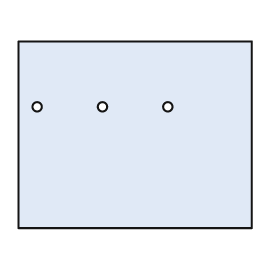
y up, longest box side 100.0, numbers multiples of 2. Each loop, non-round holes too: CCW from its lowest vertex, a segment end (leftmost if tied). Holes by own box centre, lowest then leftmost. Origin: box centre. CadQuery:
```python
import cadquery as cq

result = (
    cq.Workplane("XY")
    .moveTo(-50.0, -40.0)
    .lineTo(50.0, -40.0)
    .lineTo(50.0, 40.0)
    .lineTo(-50.0, 40.0)
    .close()
    .moveTo(-42.0, 12.0)
    .circle(2.0)
    .moveTo(-14.0, 12.0)
    .circle(2.0)
    .moveTo(14.0, 12.0)
    .circle(2.0)
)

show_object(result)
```